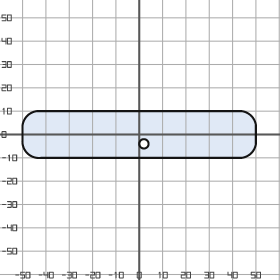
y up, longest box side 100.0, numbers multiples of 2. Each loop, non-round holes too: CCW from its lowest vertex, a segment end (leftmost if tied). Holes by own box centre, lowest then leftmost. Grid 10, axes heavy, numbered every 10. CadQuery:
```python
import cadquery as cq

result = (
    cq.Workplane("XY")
    .moveTo(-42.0, -10.0)
    .lineTo(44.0, -10.0)
    .threePointArc((48.0, -8.0), (50.0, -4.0))
    .lineTo(50.0, 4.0)
    .threePointArc((48.0, 8.0), (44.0, 10.0))
    .lineTo(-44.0, 10.0)
    .threePointArc((-48.0, 8.0), (-50.0, 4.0))
    .lineTo(-50.0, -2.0)
    .threePointArc((-48.0, -8.0), (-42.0, -10.0))
    .close()
    .moveTo(2.0, -4.0)
    .circle(2.0)
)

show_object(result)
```